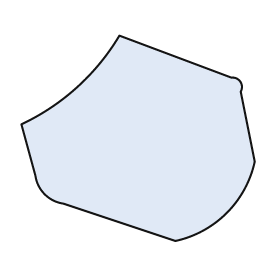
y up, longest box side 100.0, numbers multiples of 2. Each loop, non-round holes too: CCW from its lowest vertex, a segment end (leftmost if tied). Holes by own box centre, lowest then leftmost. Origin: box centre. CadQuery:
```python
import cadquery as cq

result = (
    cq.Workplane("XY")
    .moveTo(16.0, -44.0)
    .threePointArc((38.0, -32.0), (50.0, -10.0))
    .lineTo(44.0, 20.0)
    .threePointArc((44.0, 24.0), (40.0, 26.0))
    .lineTo(-8.0, 44.0)
    .threePointArc((-26.0, 22.0), (-50.0, 6.0))
    .lineTo(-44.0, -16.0)
    .threePointArc((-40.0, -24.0), (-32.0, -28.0))
    .close()
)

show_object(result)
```